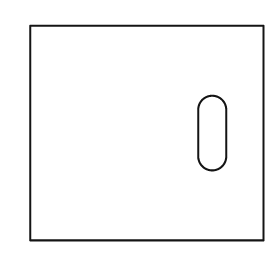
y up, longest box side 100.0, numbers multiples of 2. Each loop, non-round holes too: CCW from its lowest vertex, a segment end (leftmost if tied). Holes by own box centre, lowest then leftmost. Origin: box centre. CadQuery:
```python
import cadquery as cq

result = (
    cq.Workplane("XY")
    .moveTo(-50.0, -46.0)
    .lineTo(50.0, -46.0)
    .lineTo(50.0, 46.0)
    .lineTo(-50.0, 46.0)
    .close()
    .moveTo(22.0, -10.0)
    .threePointArc((28.0, -16.0), (34.0, -10.0))
    .lineTo(34.0, 10.0)
    .threePointArc((28.0, 16.0), (22.0, 10.0))
    .close()
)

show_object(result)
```